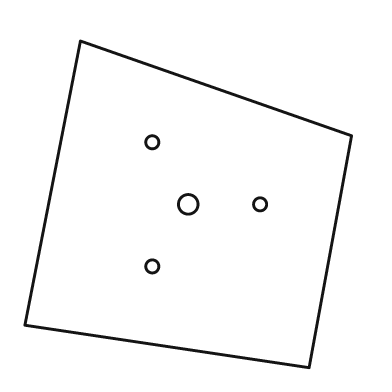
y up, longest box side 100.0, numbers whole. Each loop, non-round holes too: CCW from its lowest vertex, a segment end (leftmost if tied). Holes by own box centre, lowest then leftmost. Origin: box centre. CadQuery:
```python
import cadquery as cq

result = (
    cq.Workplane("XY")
    .moveTo(37.0, -50.0)
    .lineTo(50.0, 21.0)
    .lineTo(-33.0, 50.0)
    .lineTo(-50.0, -37.0)
    .close()
    .moveTo(-11.0, -19.0)
    .circle(2.0)
    .moveTo(0.0, 0.0)
    .circle(3.0)
    .moveTo(22.0, 0.0)
    .circle(2.0)
    .moveTo(-11.0, 19.0)
    .circle(2.0)
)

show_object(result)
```